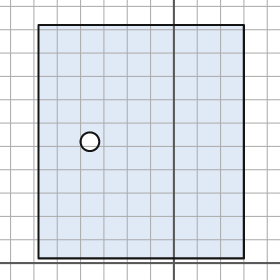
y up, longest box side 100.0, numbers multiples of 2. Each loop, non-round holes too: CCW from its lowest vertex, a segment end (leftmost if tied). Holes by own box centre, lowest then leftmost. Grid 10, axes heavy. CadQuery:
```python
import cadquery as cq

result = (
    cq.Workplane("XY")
    .moveTo(-58.0, 2.0)
    .lineTo(30.0, 2.0)
    .lineTo(30.0, 102.0)
    .lineTo(-58.0, 102.0)
    .close()
    .moveTo(-36.0, 52.0)
    .circle(4.0)
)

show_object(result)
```